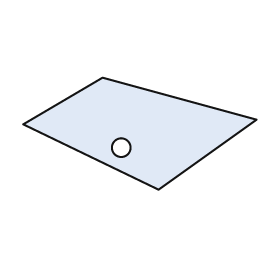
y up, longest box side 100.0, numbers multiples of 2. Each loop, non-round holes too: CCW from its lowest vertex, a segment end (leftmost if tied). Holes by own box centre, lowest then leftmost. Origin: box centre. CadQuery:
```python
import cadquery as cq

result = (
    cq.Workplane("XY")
    .moveTo(8.0, -24.0)
    .lineTo(50.0, 6.0)
    .lineTo(-16.0, 24.0)
    .lineTo(-50.0, 4.0)
    .close()
    .moveTo(-8.0, -6.0)
    .circle(4.0)
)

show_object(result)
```